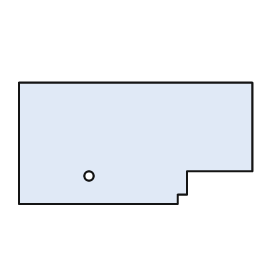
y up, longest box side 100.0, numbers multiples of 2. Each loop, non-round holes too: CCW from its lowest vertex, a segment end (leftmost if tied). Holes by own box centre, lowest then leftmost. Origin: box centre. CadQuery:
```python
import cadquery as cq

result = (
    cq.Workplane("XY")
    .moveTo(-50.0, -26.0)
    .lineTo(18.0, -26.0)
    .lineTo(18.0, -22.0)
    .lineTo(22.0, -22.0)
    .lineTo(22.0, -12.0)
    .lineTo(50.0, -12.0)
    .lineTo(50.0, 26.0)
    .lineTo(-50.0, 26.0)
    .close()
    .moveTo(-20.0, -14.0)
    .circle(2.0)
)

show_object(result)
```